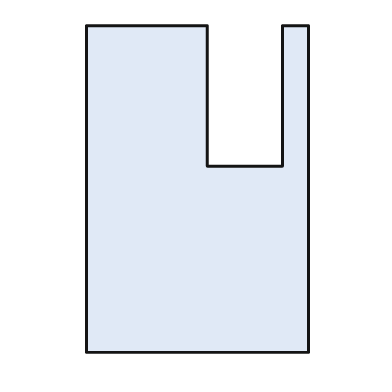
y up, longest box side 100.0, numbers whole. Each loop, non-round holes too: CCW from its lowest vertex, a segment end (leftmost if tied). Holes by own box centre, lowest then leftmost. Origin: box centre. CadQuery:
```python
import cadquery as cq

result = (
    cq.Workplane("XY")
    .moveTo(-34.0, -50.0)
    .lineTo(34.0, -50.0)
    .lineTo(34.0, 50.0)
    .lineTo(26.0, 50.0)
    .lineTo(26.0, 7.0)
    .lineTo(3.0, 7.0)
    .lineTo(3.0, 50.0)
    .lineTo(-34.0, 50.0)
    .close()
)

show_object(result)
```